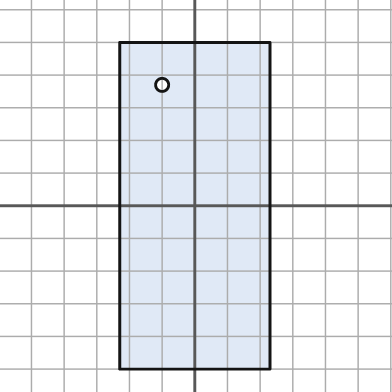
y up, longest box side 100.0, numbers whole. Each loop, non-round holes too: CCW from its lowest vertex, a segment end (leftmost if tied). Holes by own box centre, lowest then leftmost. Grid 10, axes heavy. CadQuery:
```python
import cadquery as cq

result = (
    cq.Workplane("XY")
    .moveTo(-23.0, -50.0)
    .lineTo(23.0, -50.0)
    .lineTo(23.0, 50.0)
    .lineTo(-23.0, 50.0)
    .close()
    .moveTo(-10.0, 37.0)
    .circle(2.0)
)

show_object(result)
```